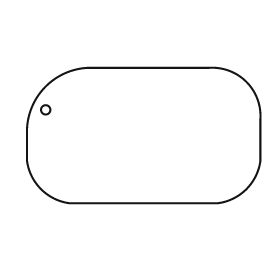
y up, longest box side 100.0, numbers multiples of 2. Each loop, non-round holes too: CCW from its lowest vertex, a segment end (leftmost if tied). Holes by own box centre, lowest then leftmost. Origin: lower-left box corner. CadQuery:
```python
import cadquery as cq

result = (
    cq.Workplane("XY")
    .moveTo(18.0, 0.0)
    .lineTo(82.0, 0.0)
    .threePointArc((94.0, 6.0), (100.0, 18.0))
    .lineTo(100.0, 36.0)
    .threePointArc((94.0, 52.0), (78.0, 58.0))
    .lineTo(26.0, 58.0)
    .threePointArc((8.0, 50.0), (0.0, 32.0))
    .lineTo(0.0, 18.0)
    .threePointArc((6.0, 6.0), (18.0, 0.0))
    .close()
    .moveTo(8.0, 40.0)
    .circle(2.0)
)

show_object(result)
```